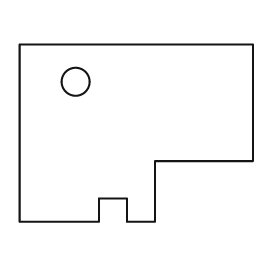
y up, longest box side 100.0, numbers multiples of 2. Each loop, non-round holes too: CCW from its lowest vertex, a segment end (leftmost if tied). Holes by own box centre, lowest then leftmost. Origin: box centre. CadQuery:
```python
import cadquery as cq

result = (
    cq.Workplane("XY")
    .moveTo(-50.0, -38.0)
    .lineTo(-16.0, -38.0)
    .lineTo(-16.0, -28.0)
    .lineTo(-4.0, -28.0)
    .lineTo(-4.0, -38.0)
    .lineTo(8.0, -38.0)
    .lineTo(8.0, -12.0)
    .lineTo(50.0, -12.0)
    .lineTo(50.0, 38.0)
    .lineTo(-50.0, 38.0)
    .close()
    .moveTo(-26.0, 22.0)
    .circle(6.0)
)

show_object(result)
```